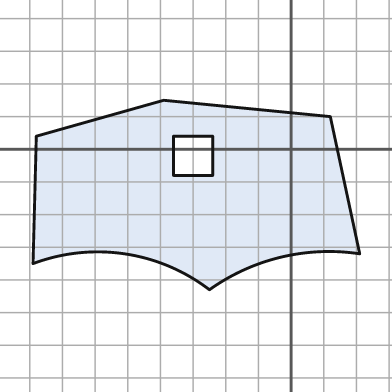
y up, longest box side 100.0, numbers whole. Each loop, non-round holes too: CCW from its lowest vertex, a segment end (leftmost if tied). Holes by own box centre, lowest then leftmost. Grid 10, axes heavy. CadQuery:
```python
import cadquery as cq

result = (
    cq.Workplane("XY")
    .moveTo(-25.0, -43.0)
    .threePointArc((-3.0, -33.0), (21.0, -32.0))
    .lineTo(12.0, 10.0)
    .lineTo(-39.0, 15.0)
    .lineTo(-78.0, 4.0)
    .lineTo(-79.0, -35.0)
    .threePointArc((-51.0, -32.0), (-25.0, -43.0))
    .close()
    .moveTo(-36.0, -8.0)
    .lineTo(-24.0, -8.0)
    .lineTo(-24.0, 4.0)
    .lineTo(-36.0, 4.0)
    .close()
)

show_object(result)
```